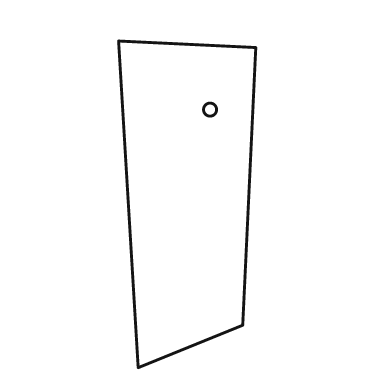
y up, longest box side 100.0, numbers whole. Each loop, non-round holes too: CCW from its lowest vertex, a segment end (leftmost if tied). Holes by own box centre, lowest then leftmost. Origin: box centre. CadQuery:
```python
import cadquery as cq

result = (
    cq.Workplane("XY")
    .moveTo(-15.0, -50.0)
    .lineTo(17.0, -37.0)
    .lineTo(21.0, 48.0)
    .lineTo(-21.0, 50.0)
    .close()
    .moveTo(7.0, 29.0)
    .circle(2.0)
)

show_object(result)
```